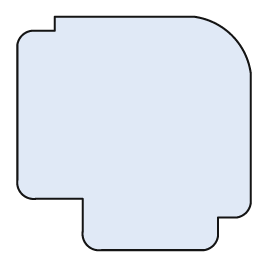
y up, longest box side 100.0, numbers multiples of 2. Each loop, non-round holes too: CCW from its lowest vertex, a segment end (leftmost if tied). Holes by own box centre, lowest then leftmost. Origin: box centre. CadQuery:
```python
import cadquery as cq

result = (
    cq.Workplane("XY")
    .moveTo(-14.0, -50.0)
    .lineTo(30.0, -50.0)
    .threePointArc((34.0, -48.0), (36.0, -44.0))
    .lineTo(36.0, -36.0)
    .lineTo(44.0, -36.0)
    .threePointArc((48.0, -34.0), (50.0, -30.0))
    .lineTo(50.0, 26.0)
    .threePointArc((42.0, 42.0), (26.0, 50.0))
    .lineTo(-34.0, 50.0)
    .lineTo(-34.0, 44.0)
    .lineTo(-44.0, 44.0)
    .threePointArc((-48.0, 42.0), (-50.0, 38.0))
    .lineTo(-50.0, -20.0)
    .threePointArc((-48.0, -26.0), (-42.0, -28.0))
    .lineTo(-22.0, -28.0)
    .lineTo(-22.0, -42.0)
    .threePointArc((-20.0, -48.0), (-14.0, -50.0))
    .close()
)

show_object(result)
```